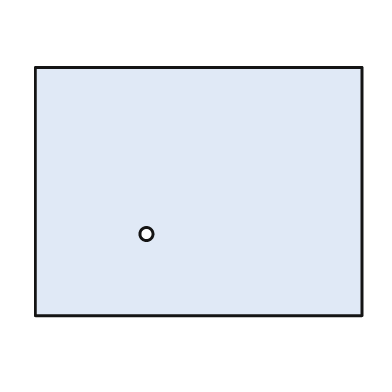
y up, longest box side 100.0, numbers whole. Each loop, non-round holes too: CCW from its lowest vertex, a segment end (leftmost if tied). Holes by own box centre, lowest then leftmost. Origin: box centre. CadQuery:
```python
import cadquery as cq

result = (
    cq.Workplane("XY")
    .moveTo(-50.0, -38.0)
    .lineTo(50.0, -38.0)
    .lineTo(50.0, 38.0)
    .lineTo(-50.0, 38.0)
    .close()
    .moveTo(-16.0, -13.0)
    .circle(2.0)
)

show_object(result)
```